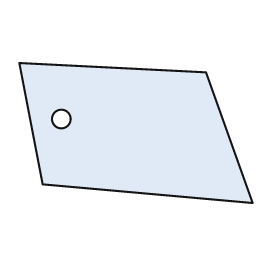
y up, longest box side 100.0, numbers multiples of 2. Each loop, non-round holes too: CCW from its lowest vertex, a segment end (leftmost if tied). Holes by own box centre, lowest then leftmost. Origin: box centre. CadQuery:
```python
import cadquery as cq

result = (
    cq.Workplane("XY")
    .moveTo(50.0, -30.0)
    .lineTo(30.0, 26.0)
    .lineTo(-50.0, 30.0)
    .lineTo(-40.0, -22.0)
    .close()
    .moveTo(-32.0, 6.0)
    .circle(4.0)
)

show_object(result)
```